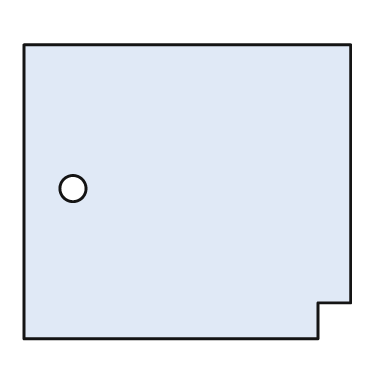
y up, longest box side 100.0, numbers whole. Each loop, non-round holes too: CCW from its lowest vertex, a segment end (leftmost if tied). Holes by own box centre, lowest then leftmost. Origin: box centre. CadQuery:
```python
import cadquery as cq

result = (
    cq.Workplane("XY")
    .moveTo(-50.0, -45.0)
    .lineTo(40.0, -45.0)
    .lineTo(40.0, -34.0)
    .lineTo(50.0, -34.0)
    .lineTo(50.0, 45.0)
    .lineTo(-50.0, 45.0)
    .close()
    .moveTo(-35.0, 1.0)
    .circle(4.0)
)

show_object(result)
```